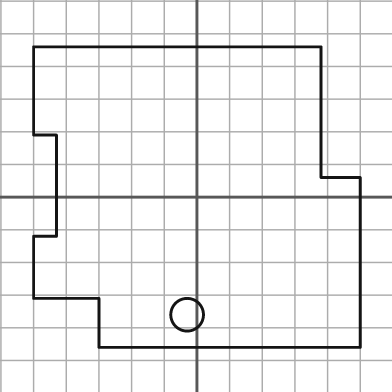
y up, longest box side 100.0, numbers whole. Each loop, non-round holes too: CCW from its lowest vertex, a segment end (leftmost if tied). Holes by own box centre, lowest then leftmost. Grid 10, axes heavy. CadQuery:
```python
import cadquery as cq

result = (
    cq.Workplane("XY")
    .moveTo(-30.0, -46.0)
    .lineTo(50.0, -46.0)
    .lineTo(50.0, 6.0)
    .lineTo(38.0, 6.0)
    .lineTo(38.0, 46.0)
    .lineTo(-50.0, 46.0)
    .lineTo(-50.0, 19.0)
    .lineTo(-43.0, 19.0)
    .lineTo(-43.0, -12.0)
    .lineTo(-50.0, -12.0)
    .lineTo(-50.0, -31.0)
    .lineTo(-30.0, -31.0)
    .close()
    .moveTo(-3.0, -36.0)
    .circle(5.0)
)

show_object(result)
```